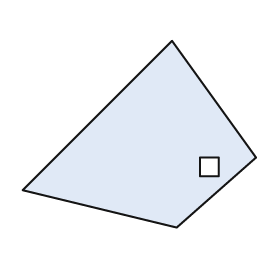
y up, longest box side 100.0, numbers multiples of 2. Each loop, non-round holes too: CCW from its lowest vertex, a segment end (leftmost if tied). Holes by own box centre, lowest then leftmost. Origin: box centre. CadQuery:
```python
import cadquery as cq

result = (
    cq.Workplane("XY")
    .moveTo(16.0, -40.0)
    .lineTo(50.0, -10.0)
    .lineTo(14.0, 40.0)
    .lineTo(-50.0, -24.0)
    .close()
    .moveTo(26.0, -18.0)
    .lineTo(34.0, -18.0)
    .lineTo(34.0, -10.0)
    .lineTo(26.0, -10.0)
    .close()
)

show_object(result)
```